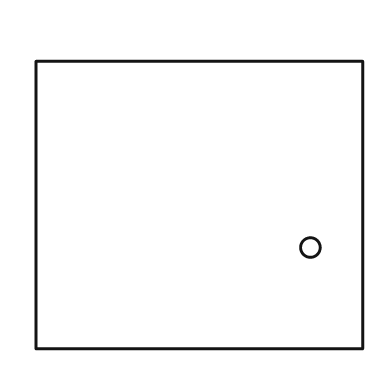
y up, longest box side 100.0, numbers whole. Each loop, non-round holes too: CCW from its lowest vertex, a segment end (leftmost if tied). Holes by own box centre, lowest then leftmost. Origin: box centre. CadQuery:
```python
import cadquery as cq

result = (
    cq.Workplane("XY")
    .moveTo(-50.0, -44.0)
    .lineTo(50.0, -44.0)
    .lineTo(50.0, 44.0)
    .lineTo(-50.0, 44.0)
    .close()
    .moveTo(34.0, -13.0)
    .circle(3.0)
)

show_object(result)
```